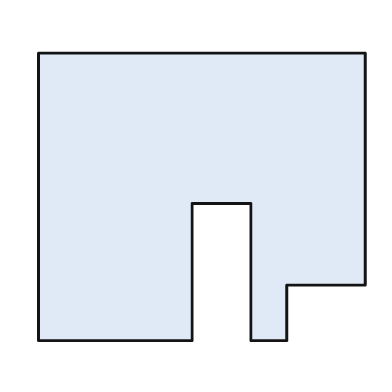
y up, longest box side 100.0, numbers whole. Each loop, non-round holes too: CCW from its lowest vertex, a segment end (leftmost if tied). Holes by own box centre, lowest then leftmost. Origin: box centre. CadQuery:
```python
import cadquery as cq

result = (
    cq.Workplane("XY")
    .moveTo(-50.0, -44.0)
    .lineTo(-3.0, -44.0)
    .lineTo(-3.0, -2.0)
    .lineTo(15.0, -2.0)
    .lineTo(15.0, -44.0)
    .lineTo(26.0, -44.0)
    .lineTo(26.0, -27.0)
    .lineTo(50.0, -27.0)
    .lineTo(50.0, 44.0)
    .lineTo(-50.0, 44.0)
    .close()
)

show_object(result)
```